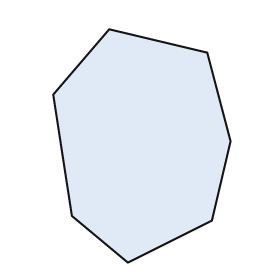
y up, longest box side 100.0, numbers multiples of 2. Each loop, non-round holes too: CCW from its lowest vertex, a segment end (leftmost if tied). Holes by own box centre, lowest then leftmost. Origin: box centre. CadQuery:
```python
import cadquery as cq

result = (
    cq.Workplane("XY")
    .moveTo(-6.0, -50.0)
    .lineTo(30.0, -32.0)
    .lineTo(38.0, 2.0)
    .lineTo(28.0, 40.0)
    .lineTo(-14.0, 50.0)
    .lineTo(-38.0, 22.0)
    .lineTo(-30.0, -30.0)
    .close()
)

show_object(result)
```